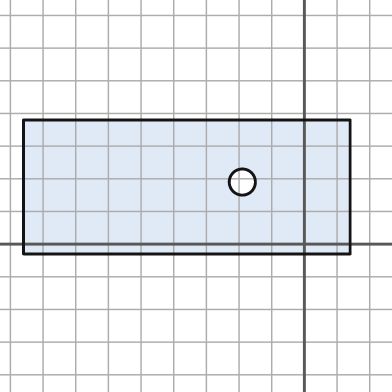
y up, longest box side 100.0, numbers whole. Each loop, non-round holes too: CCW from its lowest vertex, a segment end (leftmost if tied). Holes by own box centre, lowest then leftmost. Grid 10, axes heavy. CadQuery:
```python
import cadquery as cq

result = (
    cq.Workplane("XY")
    .moveTo(-86.0, -3.0)
    .lineTo(14.0, -3.0)
    .lineTo(14.0, 38.0)
    .lineTo(-86.0, 38.0)
    .close()
    .moveTo(-19.0, 19.0)
    .circle(4.0)
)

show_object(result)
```